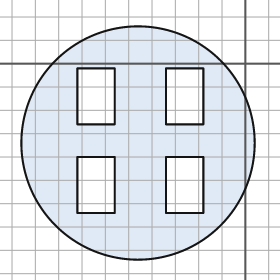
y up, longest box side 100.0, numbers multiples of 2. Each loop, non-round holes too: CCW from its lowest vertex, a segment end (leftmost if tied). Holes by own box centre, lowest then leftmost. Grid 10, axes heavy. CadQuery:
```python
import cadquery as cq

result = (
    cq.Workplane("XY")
    .moveTo(-46.0, -34.0)
    .circle(50.0)
    .moveTo(-72.0, -64.0)
    .lineTo(-56.0, -64.0)
    .lineTo(-56.0, -40.0)
    .lineTo(-72.0, -40.0)
    .close()
    .moveTo(-34.0, -64.0)
    .lineTo(-18.0, -64.0)
    .lineTo(-18.0, -40.0)
    .lineTo(-34.0, -40.0)
    .close()
    .moveTo(-72.0, -26.0)
    .lineTo(-56.0, -26.0)
    .lineTo(-56.0, -2.0)
    .lineTo(-72.0, -2.0)
    .close()
    .moveTo(-34.0, -26.0)
    .lineTo(-18.0, -26.0)
    .lineTo(-18.0, -2.0)
    .lineTo(-34.0, -2.0)
    .close()
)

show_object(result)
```